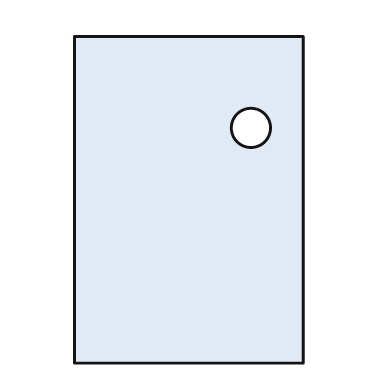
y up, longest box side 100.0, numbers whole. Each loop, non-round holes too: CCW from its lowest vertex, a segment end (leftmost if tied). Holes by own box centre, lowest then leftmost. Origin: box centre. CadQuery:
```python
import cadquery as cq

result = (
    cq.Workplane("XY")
    .moveTo(-35.0, -50.0)
    .lineTo(35.0, -50.0)
    .lineTo(35.0, 50.0)
    .lineTo(-35.0, 50.0)
    .close()
    .moveTo(19.0, 22.0)
    .circle(6.0)
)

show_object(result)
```